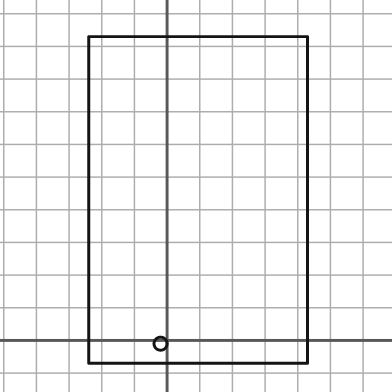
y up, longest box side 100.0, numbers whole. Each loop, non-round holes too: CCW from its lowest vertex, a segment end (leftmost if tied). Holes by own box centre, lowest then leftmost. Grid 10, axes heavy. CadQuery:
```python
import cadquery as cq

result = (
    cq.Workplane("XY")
    .moveTo(-24.0, -7.0)
    .lineTo(43.0, -7.0)
    .lineTo(43.0, 93.0)
    .lineTo(-24.0, 93.0)
    .close()
    .moveTo(-2.0, -1.0)
    .circle(2.0)
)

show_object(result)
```